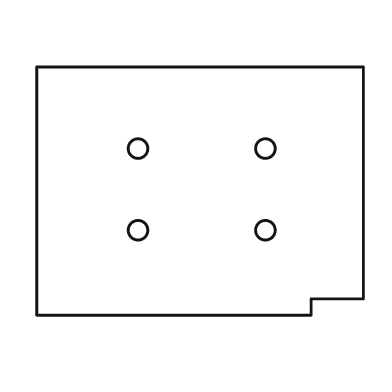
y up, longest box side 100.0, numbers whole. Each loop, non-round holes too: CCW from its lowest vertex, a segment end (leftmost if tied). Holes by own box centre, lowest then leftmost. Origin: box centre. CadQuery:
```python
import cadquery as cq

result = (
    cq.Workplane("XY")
    .moveTo(-50.0, -38.0)
    .lineTo(34.0, -38.0)
    .lineTo(34.0, -33.0)
    .lineTo(50.0, -33.0)
    .lineTo(50.0, 38.0)
    .lineTo(-50.0, 38.0)
    .close()
    .moveTo(-19.0, -12.0)
    .circle(3.0)
    .moveTo(20.0, -12.0)
    .circle(3.0)
    .moveTo(-19.0, 13.0)
    .circle(3.0)
    .moveTo(20.0, 13.0)
    .circle(3.0)
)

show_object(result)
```